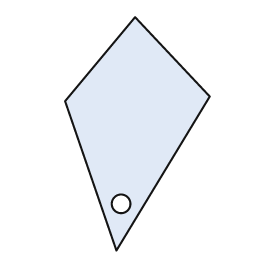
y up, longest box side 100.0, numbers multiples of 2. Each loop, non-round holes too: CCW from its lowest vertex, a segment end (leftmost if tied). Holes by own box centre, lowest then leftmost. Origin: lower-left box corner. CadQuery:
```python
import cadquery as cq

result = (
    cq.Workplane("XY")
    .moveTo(22.0, 0.0)
    .lineTo(62.0, 66.0)
    .lineTo(30.0, 100.0)
    .lineTo(0.0, 64.0)
    .close()
    .moveTo(24.0, 20.0)
    .circle(4.0)
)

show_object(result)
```